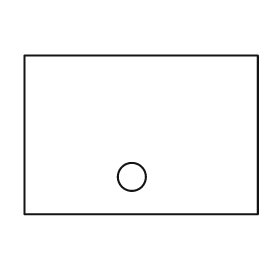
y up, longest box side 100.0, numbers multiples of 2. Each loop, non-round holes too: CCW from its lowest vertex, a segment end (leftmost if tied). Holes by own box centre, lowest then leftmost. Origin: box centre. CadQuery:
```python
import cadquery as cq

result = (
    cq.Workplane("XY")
    .moveTo(-50.0, -34.0)
    .lineTo(50.0, -34.0)
    .lineTo(50.0, 34.0)
    .lineTo(-50.0, 34.0)
    .close()
    .moveTo(-4.0, -18.0)
    .circle(6.0)
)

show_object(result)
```